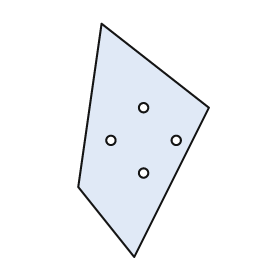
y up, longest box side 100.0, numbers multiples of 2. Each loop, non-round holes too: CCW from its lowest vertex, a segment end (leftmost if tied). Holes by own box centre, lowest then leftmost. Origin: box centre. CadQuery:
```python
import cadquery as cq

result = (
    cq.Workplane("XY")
    .moveTo(-4.0, -50.0)
    .lineTo(28.0, 14.0)
    .lineTo(-18.0, 50.0)
    .lineTo(-28.0, -20.0)
    .close()
    .moveTo(0.0, -14.0)
    .circle(2.0)
    .moveTo(-14.0, 0.0)
    .circle(2.0)
    .moveTo(14.0, 0.0)
    .circle(2.0)
    .moveTo(0.0, 14.0)
    .circle(2.0)
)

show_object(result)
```